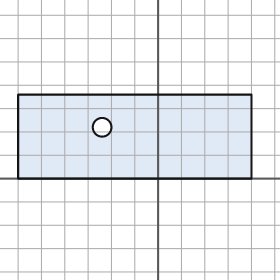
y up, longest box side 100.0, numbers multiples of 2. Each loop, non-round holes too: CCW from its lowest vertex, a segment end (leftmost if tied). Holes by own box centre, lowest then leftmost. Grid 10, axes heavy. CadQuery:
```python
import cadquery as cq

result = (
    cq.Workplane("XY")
    .moveTo(-60.0, 0.0)
    .lineTo(40.0, 0.0)
    .lineTo(40.0, 36.0)
    .lineTo(-60.0, 36.0)
    .close()
    .moveTo(-24.0, 22.0)
    .circle(4.0)
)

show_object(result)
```